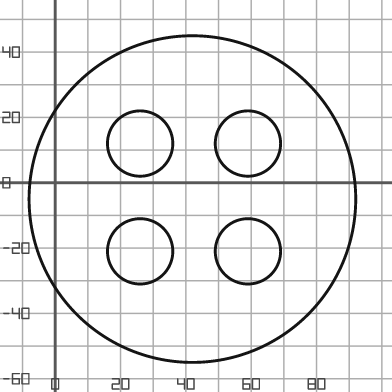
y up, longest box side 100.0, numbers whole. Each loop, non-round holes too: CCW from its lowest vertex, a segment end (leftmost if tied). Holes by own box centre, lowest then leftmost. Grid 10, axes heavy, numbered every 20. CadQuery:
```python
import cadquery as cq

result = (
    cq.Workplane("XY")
    .moveTo(42.0, -5.0)
    .circle(50.0)
    .moveTo(26.0, -21.0)
    .circle(10.0)
    .moveTo(59.0, -21.0)
    .circle(10.0)
    .moveTo(26.0, 12.0)
    .circle(10.0)
    .moveTo(59.0, 12.0)
    .circle(10.0)
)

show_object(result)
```